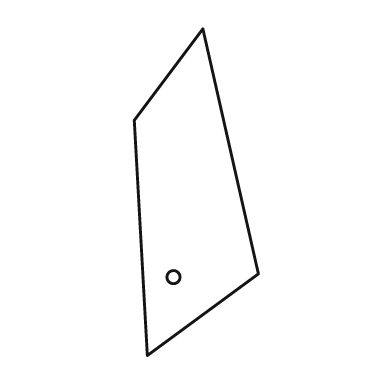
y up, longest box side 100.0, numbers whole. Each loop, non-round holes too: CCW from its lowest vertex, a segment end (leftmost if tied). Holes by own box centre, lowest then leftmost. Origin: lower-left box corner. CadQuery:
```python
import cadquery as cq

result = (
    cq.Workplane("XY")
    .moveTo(4.0, 0.0)
    .lineTo(38.0, 25.0)
    .lineTo(21.0, 100.0)
    .lineTo(0.0, 72.0)
    .close()
    .moveTo(12.0, 24.0)
    .circle(2.0)
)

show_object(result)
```